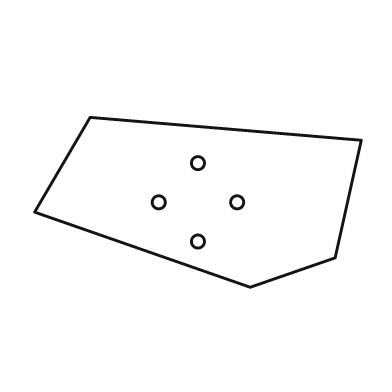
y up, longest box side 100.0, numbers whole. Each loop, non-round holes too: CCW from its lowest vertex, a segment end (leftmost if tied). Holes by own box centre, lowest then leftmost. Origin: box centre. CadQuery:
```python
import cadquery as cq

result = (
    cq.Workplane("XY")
    .moveTo(16.0, -26.0)
    .lineTo(42.0, -17.0)
    .lineTo(50.0, 19.0)
    .lineTo(-33.0, 26.0)
    .lineTo(-50.0, -3.0)
    .close()
    .moveTo(0.0, -12.0)
    .circle(2.0)
    .moveTo(-12.0, 0.0)
    .circle(2.0)
    .moveTo(12.0, 0.0)
    .circle(2.0)
    .moveTo(0.0, 12.0)
    .circle(2.0)
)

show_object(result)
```